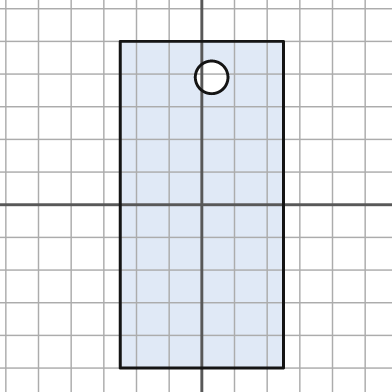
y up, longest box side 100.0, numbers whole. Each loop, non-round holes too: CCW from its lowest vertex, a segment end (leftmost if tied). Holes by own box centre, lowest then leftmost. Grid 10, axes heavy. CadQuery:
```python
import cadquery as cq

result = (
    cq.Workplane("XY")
    .moveTo(-25.0, -50.0)
    .lineTo(25.0, -50.0)
    .lineTo(25.0, 50.0)
    .lineTo(-25.0, 50.0)
    .close()
    .moveTo(3.0, 39.0)
    .circle(5.0)
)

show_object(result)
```